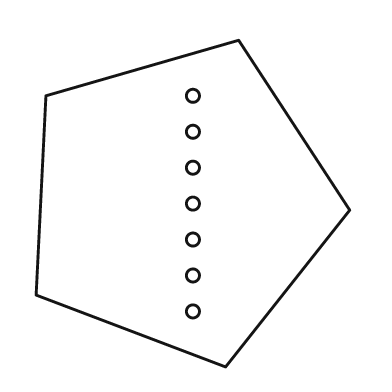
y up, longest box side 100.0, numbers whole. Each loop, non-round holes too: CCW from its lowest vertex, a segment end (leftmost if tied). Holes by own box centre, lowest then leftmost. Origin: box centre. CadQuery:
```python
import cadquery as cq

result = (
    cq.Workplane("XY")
    .moveTo(10.0, -50.0)
    .lineTo(48.0, -2.0)
    .lineTo(14.0, 50.0)
    .lineTo(-45.0, 33.0)
    .lineTo(-48.0, -28.0)
    .close()
    .moveTo(0.0, -33.0)
    .circle(2.0)
    .moveTo(0.0, -22.0)
    .circle(2.0)
    .moveTo(0.0, -11.0)
    .circle(2.0)
    .moveTo(0.0, 0.0)
    .circle(2.0)
    .moveTo(0.0, 11.0)
    .circle(2.0)
    .moveTo(0.0, 22.0)
    .circle(2.0)
    .moveTo(0.0, 33.0)
    .circle(2.0)
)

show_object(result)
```